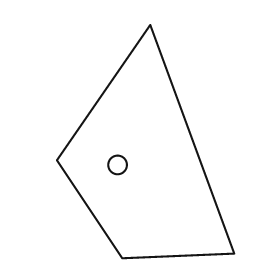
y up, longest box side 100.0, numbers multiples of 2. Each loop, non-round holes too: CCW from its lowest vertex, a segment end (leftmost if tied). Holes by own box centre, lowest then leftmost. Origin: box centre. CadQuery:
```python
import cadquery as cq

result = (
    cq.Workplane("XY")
    .moveTo(-10.0, -50.0)
    .lineTo(38.0, -48.0)
    .lineTo(2.0, 50.0)
    .lineTo(-38.0, -8.0)
    .close()
    .moveTo(-12.0, -10.0)
    .circle(4.0)
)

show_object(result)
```